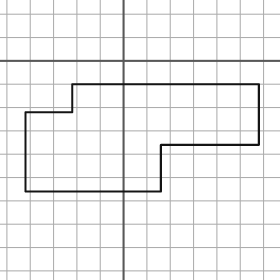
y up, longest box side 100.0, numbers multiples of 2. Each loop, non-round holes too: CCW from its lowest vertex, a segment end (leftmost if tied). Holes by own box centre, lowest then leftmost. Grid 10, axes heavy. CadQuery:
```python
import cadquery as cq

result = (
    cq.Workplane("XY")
    .moveTo(-42.0, -56.0)
    .lineTo(16.0, -56.0)
    .lineTo(16.0, -36.0)
    .lineTo(58.0, -36.0)
    .lineTo(58.0, -10.0)
    .lineTo(-22.0, -10.0)
    .lineTo(-22.0, -22.0)
    .lineTo(-42.0, -22.0)
    .close()
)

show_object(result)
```